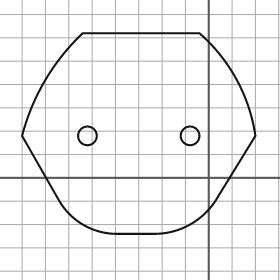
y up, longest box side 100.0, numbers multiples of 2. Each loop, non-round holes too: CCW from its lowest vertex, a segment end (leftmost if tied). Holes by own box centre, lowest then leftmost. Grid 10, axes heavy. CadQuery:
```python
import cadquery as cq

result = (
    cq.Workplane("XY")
    .moveTo(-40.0, -24.0)
    .lineTo(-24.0, -24.0)
    .threePointArc((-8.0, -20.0), (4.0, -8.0))
    .lineTo(20.0, 18.0)
    .threePointArc((12.0, 42.0), (-4.0, 62.0))
    .lineTo(-54.0, 62.0)
    .threePointArc((-70.0, 42.0), (-80.0, 18.0))
    .lineTo(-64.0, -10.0)
    .threePointArc((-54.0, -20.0), (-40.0, -24.0))
    .close()
    .moveTo(-52.0, 18.0)
    .circle(4.0)
    .moveTo(-8.0, 18.0)
    .circle(4.0)
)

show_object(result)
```